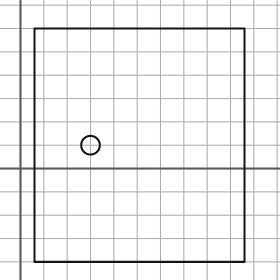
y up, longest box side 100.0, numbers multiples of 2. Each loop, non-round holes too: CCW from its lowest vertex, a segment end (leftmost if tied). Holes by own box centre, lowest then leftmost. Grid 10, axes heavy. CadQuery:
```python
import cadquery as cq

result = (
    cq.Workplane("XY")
    .moveTo(6.0, -40.0)
    .lineTo(96.0, -40.0)
    .lineTo(96.0, 60.0)
    .lineTo(6.0, 60.0)
    .close()
    .moveTo(30.0, 10.0)
    .circle(4.0)
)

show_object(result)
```